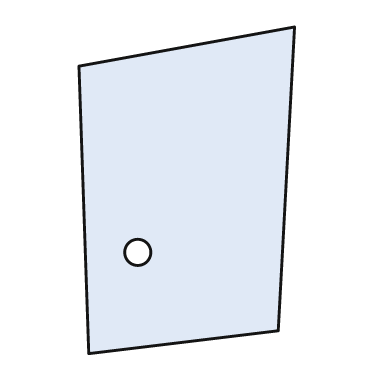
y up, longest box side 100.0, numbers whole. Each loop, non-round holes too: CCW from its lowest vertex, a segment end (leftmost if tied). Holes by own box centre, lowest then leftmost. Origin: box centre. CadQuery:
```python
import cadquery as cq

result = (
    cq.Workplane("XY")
    .moveTo(-30.0, -50.0)
    .lineTo(28.0, -43.0)
    .lineTo(33.0, 50.0)
    .lineTo(-33.0, 38.0)
    .close()
    .moveTo(-15.0, -19.0)
    .circle(4.0)
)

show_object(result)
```